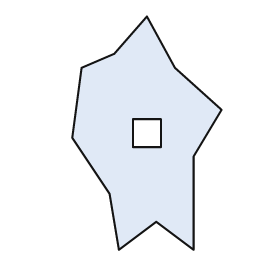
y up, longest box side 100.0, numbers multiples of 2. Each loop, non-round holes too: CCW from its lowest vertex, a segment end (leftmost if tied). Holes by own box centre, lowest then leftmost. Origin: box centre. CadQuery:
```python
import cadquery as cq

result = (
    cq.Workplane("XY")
    .moveTo(-12.0, -50.0)
    .lineTo(4.0, -38.0)
    .lineTo(20.0, -50.0)
    .lineTo(20.0, -10.0)
    .lineTo(32.0, 10.0)
    .lineTo(12.0, 28.0)
    .lineTo(0.0, 50.0)
    .lineTo(-14.0, 34.0)
    .lineTo(-28.0, 28.0)
    .lineTo(-32.0, -2.0)
    .lineTo(-16.0, -26.0)
    .close()
    .moveTo(-6.0, -6.0)
    .lineTo(6.0, -6.0)
    .lineTo(6.0, 6.0)
    .lineTo(-6.0, 6.0)
    .close()
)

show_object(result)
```